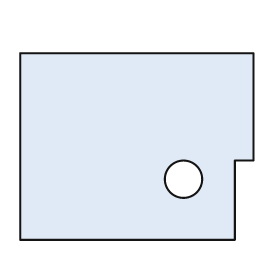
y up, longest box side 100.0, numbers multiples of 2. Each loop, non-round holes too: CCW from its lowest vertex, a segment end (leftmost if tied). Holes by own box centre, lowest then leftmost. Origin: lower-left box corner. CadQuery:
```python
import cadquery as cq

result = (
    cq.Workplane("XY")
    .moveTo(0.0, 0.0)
    .lineTo(92.0, 0.0)
    .lineTo(92.0, 34.0)
    .lineTo(100.0, 34.0)
    .lineTo(100.0, 80.0)
    .lineTo(0.0, 80.0)
    .close()
    .moveTo(70.0, 26.0)
    .circle(8.0)
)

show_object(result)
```